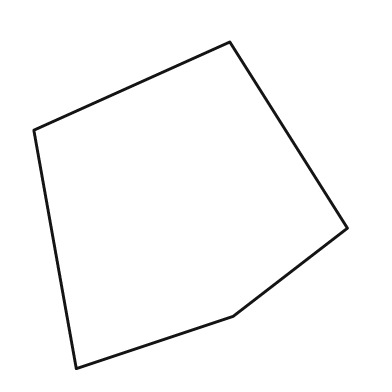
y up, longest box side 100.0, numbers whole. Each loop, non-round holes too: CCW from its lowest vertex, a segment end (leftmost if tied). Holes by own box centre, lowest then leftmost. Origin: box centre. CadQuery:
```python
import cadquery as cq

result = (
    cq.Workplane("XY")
    .moveTo(-35.0, -50.0)
    .lineTo(13.0, -34.0)
    .lineTo(48.0, -7.0)
    .lineTo(12.0, 50.0)
    .lineTo(-48.0, 23.0)
    .close()
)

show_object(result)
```